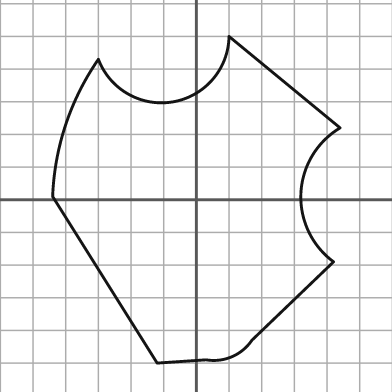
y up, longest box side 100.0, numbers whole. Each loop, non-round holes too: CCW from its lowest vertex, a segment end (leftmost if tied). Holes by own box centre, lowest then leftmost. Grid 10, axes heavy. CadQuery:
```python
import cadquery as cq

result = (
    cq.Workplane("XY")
    .moveTo(-12.0, -50.0)
    .lineTo(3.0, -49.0)
    .threePointArc((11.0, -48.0), (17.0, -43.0))
    .lineTo(42.0, -19.0)
    .threePointArc((32.0, 2.0), (44.0, 22.0))
    .lineTo(10.0, 50.0)
    .threePointArc((-7.0, 30.0), (-30.0, 43.0))
    .threePointArc((-40.0, 23.0), (-44.0, 1.0))
    .close()
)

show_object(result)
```